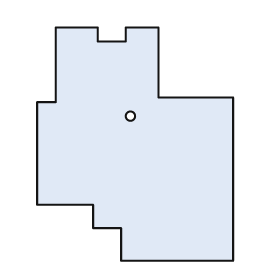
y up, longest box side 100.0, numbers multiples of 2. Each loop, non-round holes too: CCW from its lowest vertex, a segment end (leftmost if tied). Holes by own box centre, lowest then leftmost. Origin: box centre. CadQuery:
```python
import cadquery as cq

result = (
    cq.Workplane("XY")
    .moveTo(-6.0, -50.0)
    .lineTo(42.0, -50.0)
    .lineTo(42.0, 20.0)
    .lineTo(10.0, 20.0)
    .lineTo(10.0, 50.0)
    .lineTo(-4.0, 50.0)
    .lineTo(-4.0, 44.0)
    .lineTo(-16.0, 44.0)
    .lineTo(-16.0, 50.0)
    .lineTo(-34.0, 50.0)
    .lineTo(-34.0, 18.0)
    .lineTo(-42.0, 18.0)
    .lineTo(-42.0, -26.0)
    .lineTo(-18.0, -26.0)
    .lineTo(-18.0, -36.0)
    .lineTo(-6.0, -36.0)
    .close()
    .moveTo(-2.0, 12.0)
    .circle(2.0)
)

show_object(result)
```